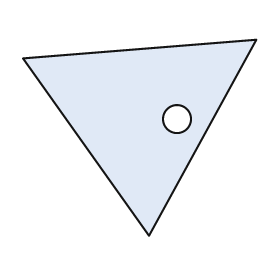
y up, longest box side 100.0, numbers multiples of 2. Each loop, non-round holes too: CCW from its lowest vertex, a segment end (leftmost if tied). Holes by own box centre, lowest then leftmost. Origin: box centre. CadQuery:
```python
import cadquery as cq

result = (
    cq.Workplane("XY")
    .moveTo(4.0, -42.0)
    .lineTo(50.0, 42.0)
    .lineTo(-50.0, 34.0)
    .close()
    .moveTo(16.0, 8.0)
    .circle(6.0)
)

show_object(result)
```